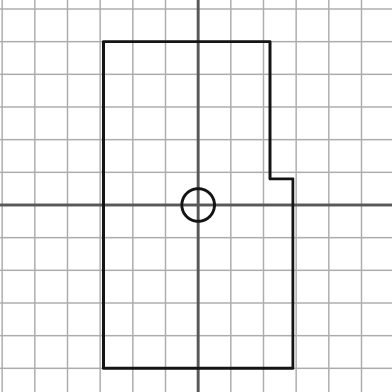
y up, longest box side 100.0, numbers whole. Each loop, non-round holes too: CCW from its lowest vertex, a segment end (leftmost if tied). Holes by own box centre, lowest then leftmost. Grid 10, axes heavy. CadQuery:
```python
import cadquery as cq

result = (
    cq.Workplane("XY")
    .moveTo(-29.0, -50.0)
    .lineTo(29.0, -50.0)
    .lineTo(29.0, 8.0)
    .lineTo(22.0, 8.0)
    .lineTo(22.0, 50.0)
    .lineTo(-29.0, 50.0)
    .close()
    .moveTo(0.0, 0.0)
    .circle(5.0)
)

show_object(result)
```